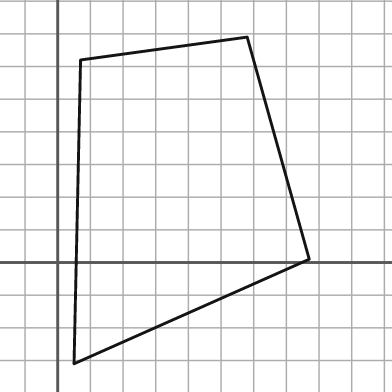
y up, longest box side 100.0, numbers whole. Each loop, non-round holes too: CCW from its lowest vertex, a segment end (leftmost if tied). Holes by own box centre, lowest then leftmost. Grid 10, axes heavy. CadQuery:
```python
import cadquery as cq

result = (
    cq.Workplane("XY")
    .moveTo(5.0, -31.0)
    .lineTo(77.0, 1.0)
    .lineTo(58.0, 69.0)
    .lineTo(7.0, 62.0)
    .close()
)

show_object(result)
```